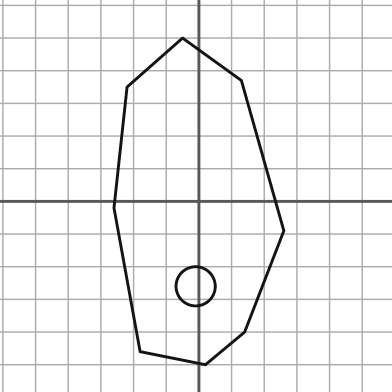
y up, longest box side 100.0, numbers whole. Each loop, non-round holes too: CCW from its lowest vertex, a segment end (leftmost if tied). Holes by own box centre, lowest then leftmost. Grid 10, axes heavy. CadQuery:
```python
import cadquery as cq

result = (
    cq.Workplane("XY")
    .moveTo(2.0, -50.0)
    .lineTo(14.0, -40.0)
    .lineTo(26.0, -9.0)
    .lineTo(13.0, 37.0)
    .lineTo(-5.0, 50.0)
    .lineTo(-22.0, 35.0)
    .lineTo(-26.0, -2.0)
    .lineTo(-18.0, -46.0)
    .close()
    .moveTo(-1.0, -26.0)
    .circle(6.0)
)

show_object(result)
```